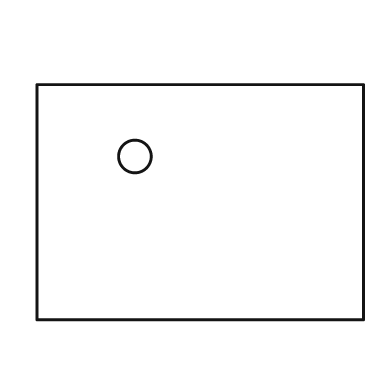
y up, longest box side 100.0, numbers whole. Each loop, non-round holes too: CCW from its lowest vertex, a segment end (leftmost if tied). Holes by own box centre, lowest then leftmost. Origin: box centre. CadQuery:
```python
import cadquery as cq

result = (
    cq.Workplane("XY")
    .moveTo(-50.0, -36.0)
    .lineTo(50.0, -36.0)
    .lineTo(50.0, 36.0)
    .lineTo(-50.0, 36.0)
    .close()
    .moveTo(-20.0, 14.0)
    .circle(5.0)
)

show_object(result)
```